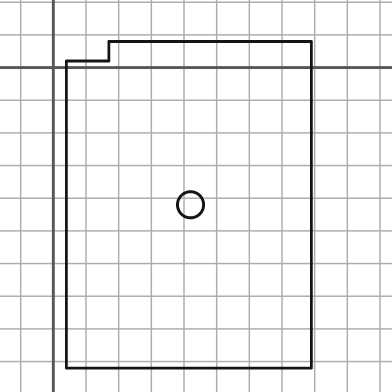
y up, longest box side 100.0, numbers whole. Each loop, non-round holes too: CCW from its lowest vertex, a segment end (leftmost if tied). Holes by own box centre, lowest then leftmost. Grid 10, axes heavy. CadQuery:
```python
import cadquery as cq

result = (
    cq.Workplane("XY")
    .moveTo(4.0, -92.0)
    .lineTo(79.0, -92.0)
    .lineTo(79.0, 8.0)
    .lineTo(17.0, 8.0)
    .lineTo(17.0, 2.0)
    .lineTo(4.0, 2.0)
    .close()
    .moveTo(42.0, -42.0)
    .circle(4.0)
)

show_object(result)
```